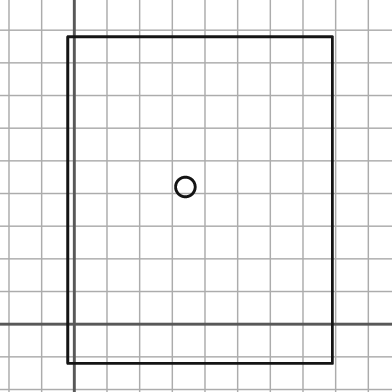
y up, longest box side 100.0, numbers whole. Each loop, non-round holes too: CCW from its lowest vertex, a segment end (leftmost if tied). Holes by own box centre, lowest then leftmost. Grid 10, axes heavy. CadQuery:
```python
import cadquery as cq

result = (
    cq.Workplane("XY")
    .moveTo(-2.0, -12.0)
    .lineTo(79.0, -12.0)
    .lineTo(79.0, 88.0)
    .lineTo(-2.0, 88.0)
    .close()
    .moveTo(34.0, 42.0)
    .circle(3.0)
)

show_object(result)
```